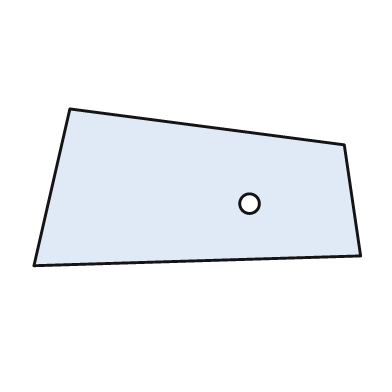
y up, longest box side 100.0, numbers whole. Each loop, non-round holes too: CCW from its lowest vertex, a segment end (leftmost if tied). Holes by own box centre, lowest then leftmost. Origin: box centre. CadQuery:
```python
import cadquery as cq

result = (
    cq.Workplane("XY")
    .moveTo(-50.0, -24.0)
    .lineTo(50.0, -21.0)
    .lineTo(45.0, 13.0)
    .lineTo(-39.0, 24.0)
    .close()
    .moveTo(16.0, -5.0)
    .circle(3.0)
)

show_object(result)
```